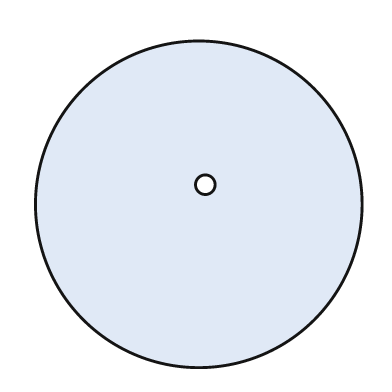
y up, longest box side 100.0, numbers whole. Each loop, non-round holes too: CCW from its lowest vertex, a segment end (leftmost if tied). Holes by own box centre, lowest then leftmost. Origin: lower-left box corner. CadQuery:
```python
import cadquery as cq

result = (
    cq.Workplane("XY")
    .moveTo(50.0, 50.0)
    .circle(50.0)
    .moveTo(52.0, 56.0)
    .circle(3.0)
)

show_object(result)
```